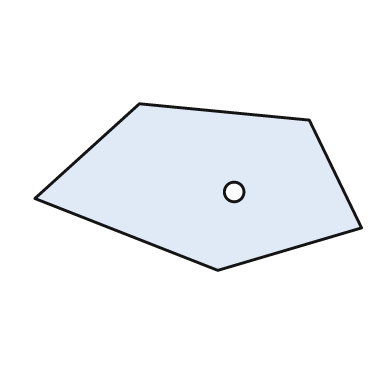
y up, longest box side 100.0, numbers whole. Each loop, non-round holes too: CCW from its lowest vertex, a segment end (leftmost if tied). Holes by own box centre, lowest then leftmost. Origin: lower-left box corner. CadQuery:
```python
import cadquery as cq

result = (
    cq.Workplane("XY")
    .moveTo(56.0, 0.0)
    .lineTo(100.0, 13.0)
    .lineTo(84.0, 46.0)
    .lineTo(32.0, 51.0)
    .lineTo(0.0, 22.0)
    .close()
    .moveTo(61.0, 24.0)
    .circle(3.0)
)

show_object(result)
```